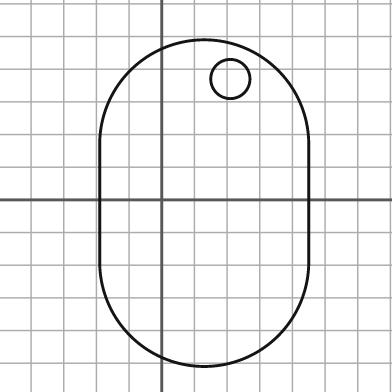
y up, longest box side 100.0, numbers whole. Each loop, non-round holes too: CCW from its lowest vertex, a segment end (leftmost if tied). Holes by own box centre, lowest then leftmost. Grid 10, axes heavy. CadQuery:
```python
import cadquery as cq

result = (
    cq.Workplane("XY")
    .moveTo(-19.0, -19.0)
    .threePointArc((13.0, -51.0), (45.0, -19.0))
    .lineTo(45.0, 17.0)
    .threePointArc((13.0, 49.0), (-19.0, 17.0))
    .close()
    .moveTo(21.0, 37.0)
    .circle(6.0)
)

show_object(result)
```